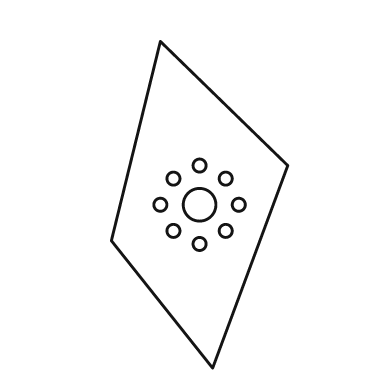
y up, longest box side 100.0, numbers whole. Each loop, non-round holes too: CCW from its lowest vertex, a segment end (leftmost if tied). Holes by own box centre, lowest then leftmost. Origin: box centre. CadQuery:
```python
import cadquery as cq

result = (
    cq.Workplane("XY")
    .moveTo(4.0, -50.0)
    .lineTo(27.0, 12.0)
    .lineTo(-12.0, 50.0)
    .lineTo(-27.0, -11.0)
    .close()
    .moveTo(0.0, -12.0)
    .circle(2.0)
    .moveTo(-8.0, -8.0)
    .circle(2.0)
    .moveTo(8.0, -8.0)
    .circle(2.0)
    .moveTo(-12.0, 0.0)
    .circle(2.0)
    .moveTo(0.0, 0.0)
    .circle(5.0)
    .moveTo(12.0, 0.0)
    .circle(2.0)
    .moveTo(-8.0, 8.0)
    .circle(2.0)
    .moveTo(8.0, 8.0)
    .circle(2.0)
    .moveTo(0.0, 12.0)
    .circle(2.0)
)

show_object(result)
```